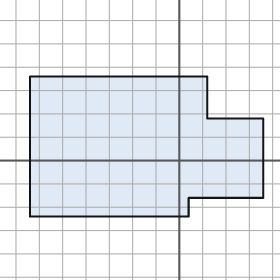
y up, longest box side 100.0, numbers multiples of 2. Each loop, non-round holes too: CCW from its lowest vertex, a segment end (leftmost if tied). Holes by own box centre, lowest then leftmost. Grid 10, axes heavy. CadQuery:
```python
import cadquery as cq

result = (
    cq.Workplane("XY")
    .moveTo(-64.0, -24.0)
    .lineTo(4.0, -24.0)
    .lineTo(4.0, -16.0)
    .lineTo(36.0, -16.0)
    .lineTo(36.0, 18.0)
    .lineTo(12.0, 18.0)
    .lineTo(12.0, 36.0)
    .lineTo(-64.0, 36.0)
    .close()
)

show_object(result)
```